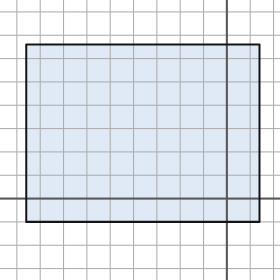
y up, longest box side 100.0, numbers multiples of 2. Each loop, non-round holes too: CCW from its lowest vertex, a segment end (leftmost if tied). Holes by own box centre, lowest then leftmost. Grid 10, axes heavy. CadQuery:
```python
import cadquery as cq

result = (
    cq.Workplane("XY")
    .moveTo(-86.0, -10.0)
    .lineTo(14.0, -10.0)
    .lineTo(14.0, 66.0)
    .lineTo(-86.0, 66.0)
    .close()
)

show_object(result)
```